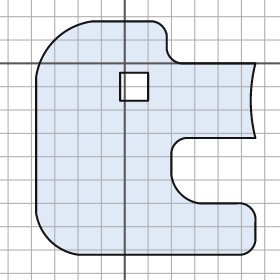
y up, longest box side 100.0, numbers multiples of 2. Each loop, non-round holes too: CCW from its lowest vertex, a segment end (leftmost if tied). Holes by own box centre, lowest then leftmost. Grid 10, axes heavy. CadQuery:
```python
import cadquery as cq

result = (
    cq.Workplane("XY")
    .moveTo(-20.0, -82.0)
    .lineTo(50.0, -82.0)
    .threePointArc((54.0, -80.0), (56.0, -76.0))
    .lineTo(56.0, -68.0)
    .threePointArc((54.0, -62.0), (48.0, -60.0))
    .lineTo(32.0, -60.0)
    .threePointArc((24.0, -56.0), (20.0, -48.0))
    .lineTo(20.0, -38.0)
    .threePointArc((22.0, -34.0), (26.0, -32.0))
    .lineTo(56.0, -32.0)
    .threePointArc((54.0, -16.0), (56.0, 0.0))
    .lineTo(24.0, 0.0)
    .threePointArc((20.0, 2.0), (18.0, 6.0))
    .lineTo(18.0, 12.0)
    .threePointArc((16.0, 16.0), (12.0, 18.0))
    .lineTo(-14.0, 18.0)
    .threePointArc((-30.0, 10.0), (-38.0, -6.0))
    .lineTo(-38.0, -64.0)
    .threePointArc((-32.0, -76.0), (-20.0, -82.0))
    .close()
    .moveTo(-2.0, -16.0)
    .lineTo(10.0, -16.0)
    .lineTo(10.0, -4.0)
    .lineTo(-2.0, -4.0)
    .close()
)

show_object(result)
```